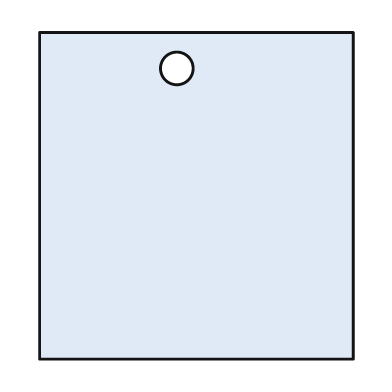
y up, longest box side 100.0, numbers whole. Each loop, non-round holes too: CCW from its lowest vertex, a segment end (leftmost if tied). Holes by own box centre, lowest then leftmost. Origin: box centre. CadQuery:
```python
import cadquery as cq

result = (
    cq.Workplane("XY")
    .moveTo(-48.0, -50.0)
    .lineTo(48.0, -50.0)
    .lineTo(48.0, 50.0)
    .lineTo(-48.0, 50.0)
    .close()
    .moveTo(-6.0, 39.0)
    .circle(5.0)
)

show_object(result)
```